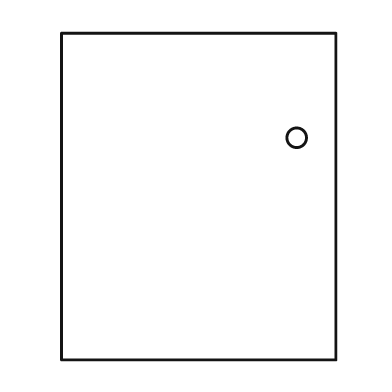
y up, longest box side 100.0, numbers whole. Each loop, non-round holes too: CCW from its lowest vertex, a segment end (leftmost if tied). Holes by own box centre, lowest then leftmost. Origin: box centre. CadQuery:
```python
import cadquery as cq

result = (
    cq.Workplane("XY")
    .moveTo(-42.0, -50.0)
    .lineTo(42.0, -50.0)
    .lineTo(42.0, 50.0)
    .lineTo(-42.0, 50.0)
    .close()
    .moveTo(30.0, 18.0)
    .circle(3.0)
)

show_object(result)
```